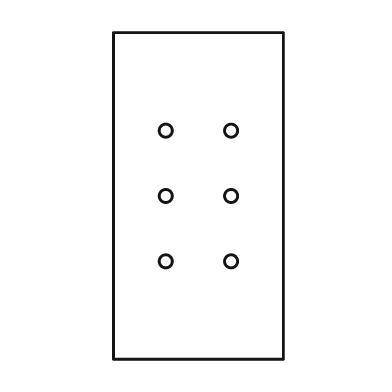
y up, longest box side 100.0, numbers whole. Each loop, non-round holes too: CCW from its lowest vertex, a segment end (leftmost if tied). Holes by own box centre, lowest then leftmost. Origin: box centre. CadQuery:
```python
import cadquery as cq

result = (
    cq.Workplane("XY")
    .moveTo(-26.0, -50.0)
    .lineTo(26.0, -50.0)
    .lineTo(26.0, 50.0)
    .lineTo(-26.0, 50.0)
    .close()
    .moveTo(-10.0, -20.0)
    .circle(2.0)
    .moveTo(10.0, -20.0)
    .circle(2.0)
    .moveTo(-10.0, 0.0)
    .circle(2.0)
    .moveTo(10.0, 0.0)
    .circle(2.0)
    .moveTo(-10.0, 20.0)
    .circle(2.0)
    .moveTo(10.0, 20.0)
    .circle(2.0)
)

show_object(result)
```